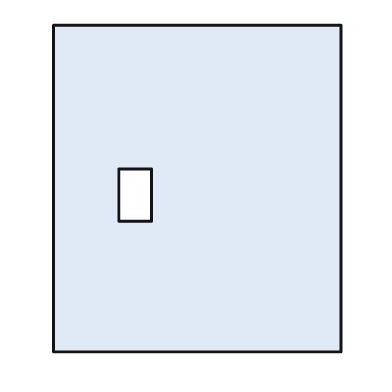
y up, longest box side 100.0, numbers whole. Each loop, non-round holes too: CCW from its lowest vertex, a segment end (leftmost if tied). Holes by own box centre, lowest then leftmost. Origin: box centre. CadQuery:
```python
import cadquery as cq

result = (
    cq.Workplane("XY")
    .moveTo(-44.0, -50.0)
    .lineTo(44.0, -50.0)
    .lineTo(44.0, 50.0)
    .lineTo(-44.0, 50.0)
    .close()
    .moveTo(-24.0, -10.0)
    .lineTo(-14.0, -10.0)
    .lineTo(-14.0, 6.0)
    .lineTo(-24.0, 6.0)
    .close()
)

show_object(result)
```